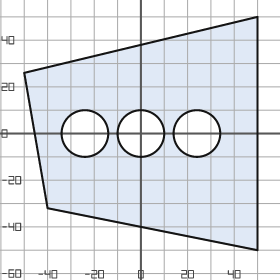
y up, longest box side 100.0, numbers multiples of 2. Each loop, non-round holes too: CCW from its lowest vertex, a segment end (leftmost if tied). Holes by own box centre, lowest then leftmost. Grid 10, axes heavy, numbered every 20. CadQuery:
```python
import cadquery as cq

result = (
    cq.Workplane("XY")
    .moveTo(50.0, -50.0)
    .lineTo(50.0, 50.0)
    .lineTo(-50.0, 26.0)
    .lineTo(-40.0, -32.0)
    .close()
    .moveTo(-24.0, 0.0)
    .circle(10.0)
    .moveTo(0.0, 0.0)
    .circle(10.0)
    .moveTo(24.0, 0.0)
    .circle(10.0)
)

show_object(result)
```